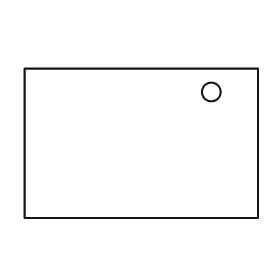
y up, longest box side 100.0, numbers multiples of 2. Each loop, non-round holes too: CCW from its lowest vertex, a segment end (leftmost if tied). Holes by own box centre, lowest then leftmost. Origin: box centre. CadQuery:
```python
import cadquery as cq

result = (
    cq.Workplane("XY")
    .moveTo(-50.0, -32.0)
    .lineTo(50.0, -32.0)
    .lineTo(50.0, 32.0)
    .lineTo(-50.0, 32.0)
    .close()
    .moveTo(30.0, 22.0)
    .circle(4.0)
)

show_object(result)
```